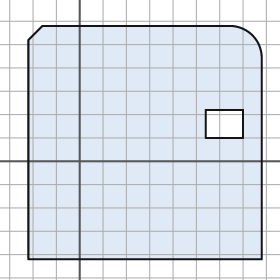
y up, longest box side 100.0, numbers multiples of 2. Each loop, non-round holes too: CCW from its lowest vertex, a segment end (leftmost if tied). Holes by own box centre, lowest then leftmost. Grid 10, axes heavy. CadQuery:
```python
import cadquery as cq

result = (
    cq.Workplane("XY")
    .moveTo(-22.0, -42.0)
    .lineTo(78.0, -42.0)
    .lineTo(78.0, 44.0)
    .threePointArc((74.0, 54.0), (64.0, 58.0))
    .lineTo(-16.0, 58.0)
    .lineTo(-22.0, 52.0)
    .close()
    .moveTo(54.0, 10.0)
    .lineTo(70.0, 10.0)
    .lineTo(70.0, 22.0)
    .lineTo(54.0, 22.0)
    .close()
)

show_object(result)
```